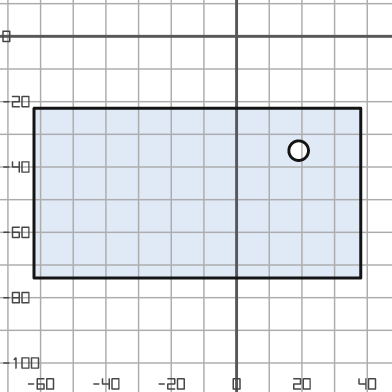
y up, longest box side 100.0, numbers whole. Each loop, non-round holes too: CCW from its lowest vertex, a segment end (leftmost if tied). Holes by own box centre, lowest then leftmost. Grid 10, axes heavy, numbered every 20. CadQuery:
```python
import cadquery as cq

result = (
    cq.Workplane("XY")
    .moveTo(-62.0, -74.0)
    .lineTo(38.0, -74.0)
    .lineTo(38.0, -22.0)
    .lineTo(-62.0, -22.0)
    .close()
    .moveTo(19.0, -35.0)
    .circle(3.0)
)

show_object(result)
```